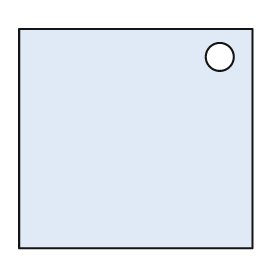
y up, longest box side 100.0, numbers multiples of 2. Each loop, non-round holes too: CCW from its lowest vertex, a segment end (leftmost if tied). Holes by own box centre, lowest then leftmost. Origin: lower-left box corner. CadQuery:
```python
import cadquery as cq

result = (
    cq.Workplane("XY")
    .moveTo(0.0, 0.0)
    .lineTo(100.0, 0.0)
    .lineTo(100.0, 94.0)
    .lineTo(0.0, 94.0)
    .close()
    .moveTo(86.0, 82.0)
    .circle(6.0)
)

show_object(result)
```